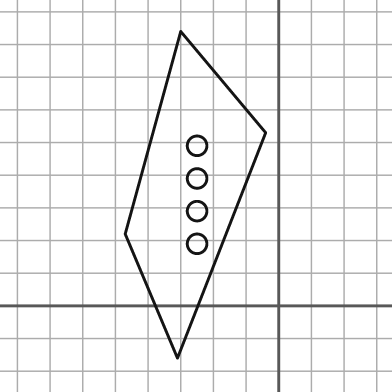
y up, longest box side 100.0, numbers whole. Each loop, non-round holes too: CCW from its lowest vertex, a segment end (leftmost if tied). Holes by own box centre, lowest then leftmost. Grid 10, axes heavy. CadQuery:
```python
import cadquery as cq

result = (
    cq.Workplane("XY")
    .moveTo(-31.0, -16.0)
    .lineTo(-4.0, 53.0)
    .lineTo(-30.0, 84.0)
    .lineTo(-47.0, 22.0)
    .close()
    .moveTo(-25.0, 19.0)
    .circle(3.0)
    .moveTo(-25.0, 29.0)
    .circle(3.0)
    .moveTo(-25.0, 39.0)
    .circle(3.0)
    .moveTo(-25.0, 49.0)
    .circle(3.0)
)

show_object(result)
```